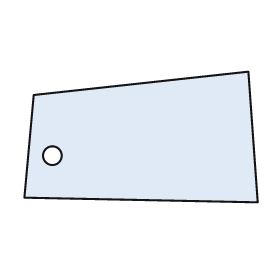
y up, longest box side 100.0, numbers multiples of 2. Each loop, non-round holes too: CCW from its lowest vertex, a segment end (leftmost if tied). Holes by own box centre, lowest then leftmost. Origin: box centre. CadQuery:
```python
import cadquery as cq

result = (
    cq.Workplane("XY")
    .moveTo(50.0, -28.0)
    .lineTo(46.0, 28.0)
    .lineTo(-46.0, 18.0)
    .lineTo(-50.0, -26.0)
    .close()
    .moveTo(-38.0, -8.0)
    .circle(4.0)
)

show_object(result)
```